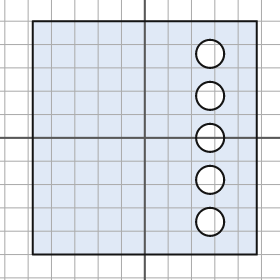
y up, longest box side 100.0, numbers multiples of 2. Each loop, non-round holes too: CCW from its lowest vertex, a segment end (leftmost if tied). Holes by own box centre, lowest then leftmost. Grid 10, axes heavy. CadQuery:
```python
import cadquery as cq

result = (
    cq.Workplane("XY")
    .moveTo(-48.0, -50.0)
    .lineTo(48.0, -50.0)
    .lineTo(48.0, 50.0)
    .lineTo(-48.0, 50.0)
    .close()
    .moveTo(28.0, -36.0)
    .circle(6.0)
    .moveTo(28.0, -18.0)
    .circle(6.0)
    .moveTo(28.0, 0.0)
    .circle(6.0)
    .moveTo(28.0, 18.0)
    .circle(6.0)
    .moveTo(28.0, 36.0)
    .circle(6.0)
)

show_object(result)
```